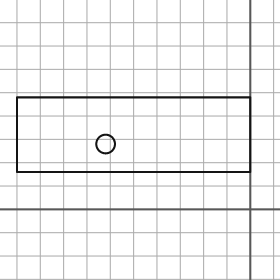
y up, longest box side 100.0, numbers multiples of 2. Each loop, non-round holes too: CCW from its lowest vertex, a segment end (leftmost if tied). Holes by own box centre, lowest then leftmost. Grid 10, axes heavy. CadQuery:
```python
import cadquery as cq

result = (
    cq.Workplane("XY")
    .moveTo(-100.0, 16.0)
    .lineTo(0.0, 16.0)
    .lineTo(0.0, 48.0)
    .lineTo(-100.0, 48.0)
    .close()
    .moveTo(-62.0, 28.0)
    .circle(4.0)
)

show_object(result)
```